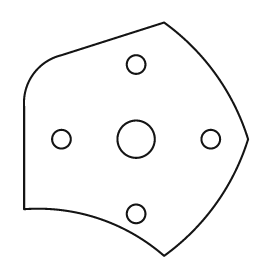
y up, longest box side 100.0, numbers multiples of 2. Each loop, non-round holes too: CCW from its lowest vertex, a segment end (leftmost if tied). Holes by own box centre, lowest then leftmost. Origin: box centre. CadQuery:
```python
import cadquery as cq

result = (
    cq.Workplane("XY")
    .moveTo(12.0, -50.0)
    .threePointArc((34.0, -28.0), (48.0, 0.0))
    .threePointArc((34.0, 28.0), (12.0, 50.0))
    .lineTo(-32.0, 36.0)
    .threePointArc((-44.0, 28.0), (-48.0, 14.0))
    .lineTo(-48.0, -30.0)
    .threePointArc((-16.0, -34.0), (12.0, -50.0))
    .close()
    .moveTo(0.0, -32.0)
    .circle(4.0)
    .moveTo(-32.0, 0.0)
    .circle(4.0)
    .moveTo(0.0, 0.0)
    .circle(8.0)
    .moveTo(32.0, 0.0)
    .circle(4.0)
    .moveTo(0.0, 32.0)
    .circle(4.0)
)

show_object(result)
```